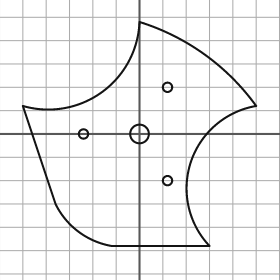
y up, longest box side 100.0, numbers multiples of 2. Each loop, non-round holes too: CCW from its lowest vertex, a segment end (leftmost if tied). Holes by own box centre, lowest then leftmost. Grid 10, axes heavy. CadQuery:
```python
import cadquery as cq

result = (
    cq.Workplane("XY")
    .moveTo(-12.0, -48.0)
    .lineTo(30.0, -48.0)
    .threePointArc((22.0, -12.0), (50.0, 12.0))
    .threePointArc((28.0, 34.0), (0.0, 48.0))
    .threePointArc((-16.0, 18.0), (-50.0, 12.0))
    .lineTo(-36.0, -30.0)
    .threePointArc((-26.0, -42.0), (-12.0, -48.0))
    .close()
    .moveTo(12.0, -20.0)
    .circle(2.0)
    .moveTo(-24.0, 0.0)
    .circle(2.0)
    .moveTo(0.0, 0.0)
    .circle(4.0)
    .moveTo(12.0, 20.0)
    .circle(2.0)
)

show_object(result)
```